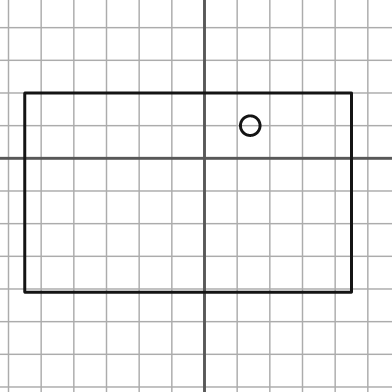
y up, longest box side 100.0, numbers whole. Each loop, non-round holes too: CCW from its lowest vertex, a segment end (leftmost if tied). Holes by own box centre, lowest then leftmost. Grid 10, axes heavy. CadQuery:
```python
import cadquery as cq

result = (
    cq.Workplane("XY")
    .moveTo(-55.0, -41.0)
    .lineTo(45.0, -41.0)
    .lineTo(45.0, 20.0)
    .lineTo(-55.0, 20.0)
    .close()
    .moveTo(14.0, 10.0)
    .circle(3.0)
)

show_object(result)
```